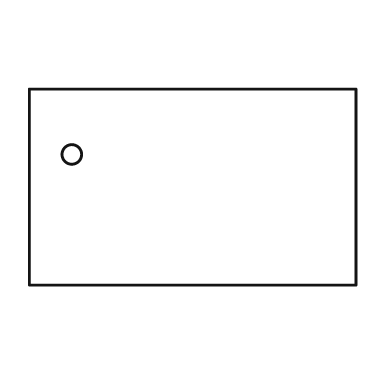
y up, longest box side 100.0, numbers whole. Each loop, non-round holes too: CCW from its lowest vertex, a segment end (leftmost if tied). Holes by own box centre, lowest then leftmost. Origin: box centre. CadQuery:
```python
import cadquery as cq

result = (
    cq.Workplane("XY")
    .moveTo(-50.0, -30.0)
    .lineTo(50.0, -30.0)
    .lineTo(50.0, 30.0)
    .lineTo(-50.0, 30.0)
    .close()
    .moveTo(-37.0, 10.0)
    .circle(3.0)
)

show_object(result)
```